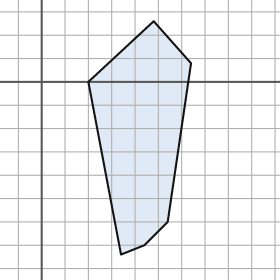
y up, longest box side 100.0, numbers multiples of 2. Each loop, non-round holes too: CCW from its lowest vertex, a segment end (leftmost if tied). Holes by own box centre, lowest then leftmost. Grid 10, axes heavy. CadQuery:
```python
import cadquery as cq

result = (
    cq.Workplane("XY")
    .moveTo(34.0, -74.0)
    .lineTo(44.0, -70.0)
    .lineTo(54.0, -60.0)
    .lineTo(64.0, 8.0)
    .lineTo(48.0, 26.0)
    .lineTo(20.0, 0.0)
    .close()
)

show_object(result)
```